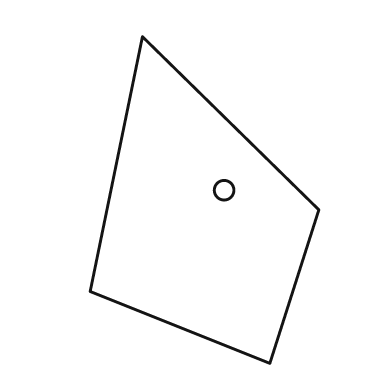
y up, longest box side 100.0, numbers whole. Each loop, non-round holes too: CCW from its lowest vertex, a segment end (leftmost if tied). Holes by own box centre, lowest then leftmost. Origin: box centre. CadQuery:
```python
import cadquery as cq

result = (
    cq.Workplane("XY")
    .moveTo(20.0, -50.0)
    .lineTo(35.0, -3.0)
    .lineTo(-19.0, 50.0)
    .lineTo(-35.0, -28.0)
    .close()
    .moveTo(6.0, 3.0)
    .circle(3.0)
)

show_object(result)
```